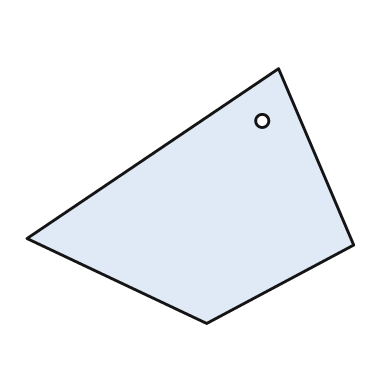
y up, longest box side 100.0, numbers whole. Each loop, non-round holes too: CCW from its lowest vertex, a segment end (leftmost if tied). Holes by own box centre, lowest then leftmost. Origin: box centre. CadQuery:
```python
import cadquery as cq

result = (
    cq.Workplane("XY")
    .moveTo(5.0, -39.0)
    .lineTo(50.0, -15.0)
    .lineTo(27.0, 39.0)
    .lineTo(-50.0, -13.0)
    .close()
    .moveTo(22.0, 23.0)
    .circle(2.0)
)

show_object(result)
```